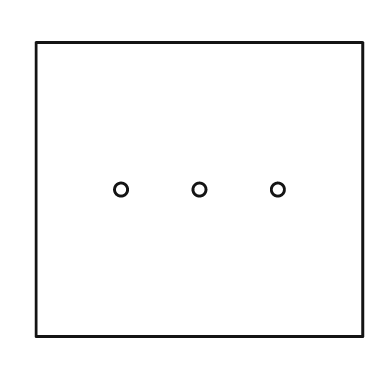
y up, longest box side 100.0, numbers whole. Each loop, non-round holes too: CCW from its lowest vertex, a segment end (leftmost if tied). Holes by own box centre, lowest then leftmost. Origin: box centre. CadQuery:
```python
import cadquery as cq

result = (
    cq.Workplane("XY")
    .moveTo(-50.0, -45.0)
    .lineTo(50.0, -45.0)
    .lineTo(50.0, 45.0)
    .lineTo(-50.0, 45.0)
    .close()
    .moveTo(-24.0, 0.0)
    .circle(2.0)
    .moveTo(0.0, 0.0)
    .circle(2.0)
    .moveTo(24.0, 0.0)
    .circle(2.0)
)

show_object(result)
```